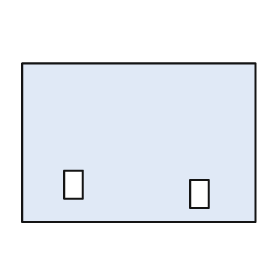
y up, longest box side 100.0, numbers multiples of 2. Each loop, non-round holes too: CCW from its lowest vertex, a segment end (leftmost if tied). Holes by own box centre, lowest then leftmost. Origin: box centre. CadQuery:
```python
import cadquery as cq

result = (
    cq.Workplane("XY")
    .moveTo(-50.0, -34.0)
    .lineTo(50.0, -34.0)
    .lineTo(50.0, 34.0)
    .lineTo(-50.0, 34.0)
    .close()
    .moveTo(22.0, -28.0)
    .lineTo(30.0, -28.0)
    .lineTo(30.0, -16.0)
    .lineTo(22.0, -16.0)
    .close()
    .moveTo(-32.0, -24.0)
    .lineTo(-24.0, -24.0)
    .lineTo(-24.0, -12.0)
    .lineTo(-32.0, -12.0)
    .close()
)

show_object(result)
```